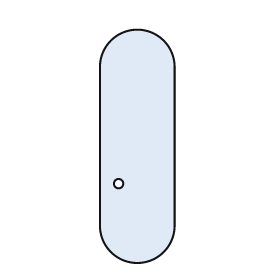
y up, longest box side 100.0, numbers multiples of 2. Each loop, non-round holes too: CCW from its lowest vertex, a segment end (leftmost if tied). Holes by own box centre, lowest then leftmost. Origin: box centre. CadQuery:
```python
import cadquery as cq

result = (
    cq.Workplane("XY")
    .moveTo(-16.0, -34.0)
    .threePointArc((0.0, -50.0), (16.0, -34.0))
    .lineTo(16.0, 34.0)
    .threePointArc((0.0, 50.0), (-16.0, 34.0))
    .close()
    .moveTo(-8.0, -16.0)
    .circle(2.0)
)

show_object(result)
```